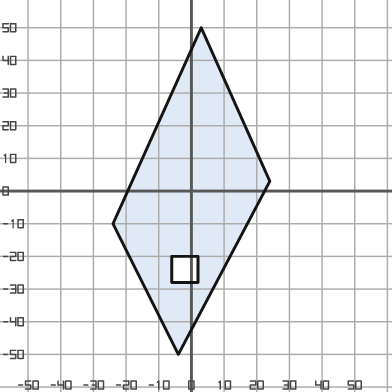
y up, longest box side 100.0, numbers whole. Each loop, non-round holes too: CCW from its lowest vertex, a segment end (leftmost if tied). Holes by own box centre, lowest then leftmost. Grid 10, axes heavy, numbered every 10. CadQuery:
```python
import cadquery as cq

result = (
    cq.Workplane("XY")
    .moveTo(-4.0, -50.0)
    .lineTo(24.0, 3.0)
    .lineTo(3.0, 50.0)
    .lineTo(-24.0, -10.0)
    .close()
    .moveTo(-6.0, -28.0)
    .lineTo(2.0, -28.0)
    .lineTo(2.0, -20.0)
    .lineTo(-6.0, -20.0)
    .close()
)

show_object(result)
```